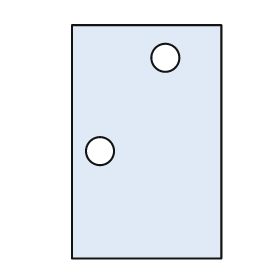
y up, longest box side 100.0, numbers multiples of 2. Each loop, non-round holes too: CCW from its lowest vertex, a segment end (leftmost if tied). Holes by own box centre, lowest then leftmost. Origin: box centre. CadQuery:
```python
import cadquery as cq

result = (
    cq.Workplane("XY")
    .moveTo(-32.0, -50.0)
    .lineTo(32.0, -50.0)
    .lineTo(32.0, 50.0)
    .lineTo(-32.0, 50.0)
    .close()
    .moveTo(-20.0, -4.0)
    .circle(6.0)
    .moveTo(8.0, 36.0)
    .circle(6.0)
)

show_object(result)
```